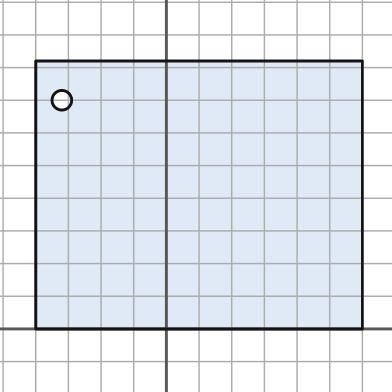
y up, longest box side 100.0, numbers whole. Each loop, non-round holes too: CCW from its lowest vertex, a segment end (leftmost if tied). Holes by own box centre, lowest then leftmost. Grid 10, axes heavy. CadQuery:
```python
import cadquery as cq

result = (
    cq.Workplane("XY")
    .moveTo(-40.0, 0.0)
    .lineTo(60.0, 0.0)
    .lineTo(60.0, 82.0)
    .lineTo(-40.0, 82.0)
    .close()
    .moveTo(-32.0, 70.0)
    .circle(3.0)
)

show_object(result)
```